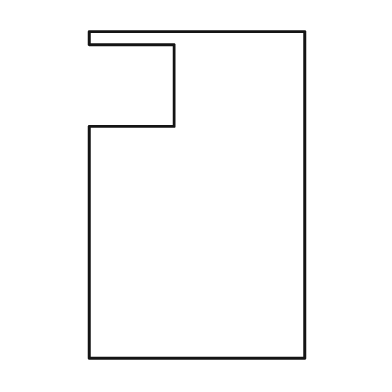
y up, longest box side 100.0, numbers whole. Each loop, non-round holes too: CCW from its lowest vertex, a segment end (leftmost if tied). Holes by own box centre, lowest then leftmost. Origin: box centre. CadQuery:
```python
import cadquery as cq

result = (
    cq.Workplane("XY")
    .moveTo(-33.0, -50.0)
    .lineTo(33.0, -50.0)
    .lineTo(33.0, 50.0)
    .lineTo(-33.0, 50.0)
    .lineTo(-33.0, 46.0)
    .lineTo(-7.0, 46.0)
    .lineTo(-7.0, 21.0)
    .lineTo(-33.0, 21.0)
    .close()
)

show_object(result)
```